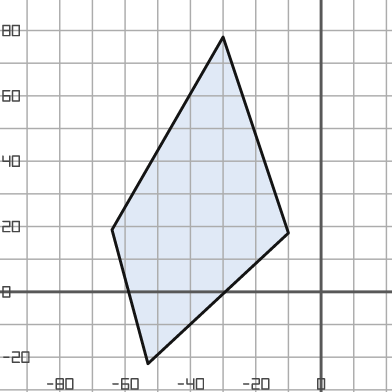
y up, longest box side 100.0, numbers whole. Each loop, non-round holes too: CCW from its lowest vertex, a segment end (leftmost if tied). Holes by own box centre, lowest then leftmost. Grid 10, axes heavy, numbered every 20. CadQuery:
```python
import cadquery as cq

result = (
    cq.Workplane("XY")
    .moveTo(-53.0, -22.0)
    .lineTo(-10.0, 18.0)
    .lineTo(-30.0, 78.0)
    .lineTo(-64.0, 19.0)
    .close()
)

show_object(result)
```